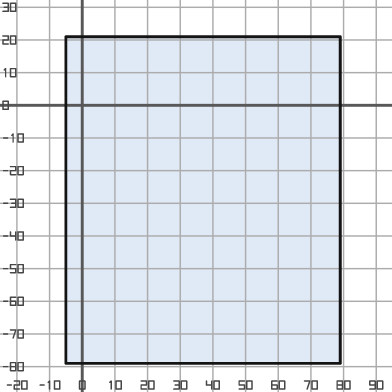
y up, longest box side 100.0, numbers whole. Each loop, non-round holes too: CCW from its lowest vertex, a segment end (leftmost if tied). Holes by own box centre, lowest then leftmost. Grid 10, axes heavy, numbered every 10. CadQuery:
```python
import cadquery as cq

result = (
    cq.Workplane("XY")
    .moveTo(-5.0, -79.0)
    .lineTo(79.0, -79.0)
    .lineTo(79.0, 21.0)
    .lineTo(-5.0, 21.0)
    .close()
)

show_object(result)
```